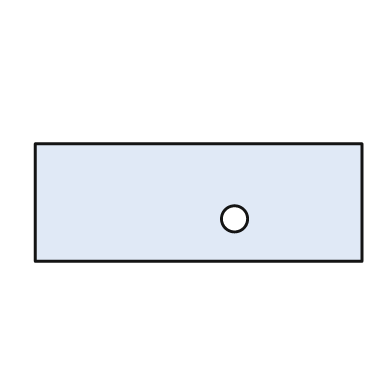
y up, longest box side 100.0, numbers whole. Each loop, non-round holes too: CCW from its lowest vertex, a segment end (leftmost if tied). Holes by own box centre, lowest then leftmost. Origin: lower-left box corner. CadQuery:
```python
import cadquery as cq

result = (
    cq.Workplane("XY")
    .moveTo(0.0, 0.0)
    .lineTo(100.0, 0.0)
    .lineTo(100.0, 36.0)
    .lineTo(0.0, 36.0)
    .close()
    .moveTo(61.0, 13.0)
    .circle(4.0)
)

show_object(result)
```